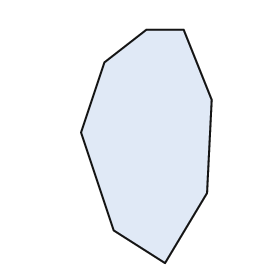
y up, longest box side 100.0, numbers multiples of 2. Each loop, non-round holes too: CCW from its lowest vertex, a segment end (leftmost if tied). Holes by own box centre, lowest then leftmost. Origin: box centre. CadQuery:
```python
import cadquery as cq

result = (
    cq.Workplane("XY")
    .moveTo(8.0, -50.0)
    .lineTo(26.0, -20.0)
    .lineTo(28.0, 20.0)
    .lineTo(16.0, 50.0)
    .lineTo(0.0, 50.0)
    .lineTo(-18.0, 36.0)
    .lineTo(-28.0, 6.0)
    .lineTo(-14.0, -36.0)
    .close()
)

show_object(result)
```